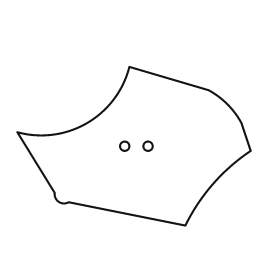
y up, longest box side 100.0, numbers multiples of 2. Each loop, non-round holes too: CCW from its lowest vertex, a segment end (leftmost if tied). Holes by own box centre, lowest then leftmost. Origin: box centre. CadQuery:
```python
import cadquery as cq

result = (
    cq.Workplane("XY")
    .moveTo(22.0, -34.0)
    .threePointArc((34.0, -16.0), (50.0, -2.0))
    .lineTo(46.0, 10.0)
    .threePointArc((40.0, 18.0), (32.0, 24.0))
    .lineTo(-2.0, 34.0)
    .threePointArc((-20.0, 10.0), (-50.0, 6.0))
    .lineTo(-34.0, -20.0)
    .threePointArc((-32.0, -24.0), (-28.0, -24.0))
    .close()
    .moveTo(-4.0, 0.0)
    .circle(2.0)
    .moveTo(6.0, 0.0)
    .circle(2.0)
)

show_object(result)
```